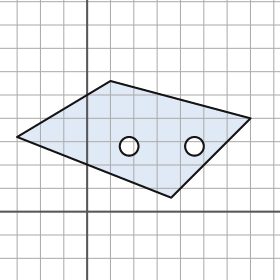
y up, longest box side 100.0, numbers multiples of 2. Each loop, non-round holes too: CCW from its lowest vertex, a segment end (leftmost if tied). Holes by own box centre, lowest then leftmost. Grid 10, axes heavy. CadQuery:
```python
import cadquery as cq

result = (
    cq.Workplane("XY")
    .moveTo(36.0, 6.0)
    .lineTo(70.0, 40.0)
    .lineTo(10.0, 56.0)
    .lineTo(-30.0, 32.0)
    .close()
    .moveTo(18.0, 28.0)
    .circle(4.0)
    .moveTo(46.0, 28.0)
    .circle(4.0)
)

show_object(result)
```